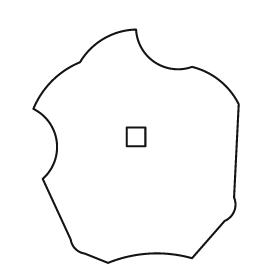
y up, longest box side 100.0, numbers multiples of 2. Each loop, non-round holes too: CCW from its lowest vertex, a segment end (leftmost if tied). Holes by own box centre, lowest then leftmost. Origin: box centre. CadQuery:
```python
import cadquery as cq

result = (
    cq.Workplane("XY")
    .moveTo(-12.0, -50.0)
    .threePointArc((6.0, -46.0), (24.0, -48.0))
    .lineTo(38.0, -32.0)
    .threePointArc((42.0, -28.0), (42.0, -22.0))
    .lineTo(44.0, 18.0)
    .threePointArc((36.0, 28.0), (24.0, 34.0))
    .threePointArc((8.0, 36.0), (0.0, 50.0))
    .threePointArc((-14.0, 46.0), (-24.0, 36.0))
    .threePointArc((-36.0, 28.0), (-44.0, 16.0))
    .threePointArc((-34.0, 2.0), (-40.0, -14.0))
    .lineTo(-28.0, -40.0)
    .threePointArc((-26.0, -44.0), (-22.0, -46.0))
    .close()
    .moveTo(-4.0, 0.0)
    .lineTo(4.0, 0.0)
    .lineTo(4.0, 8.0)
    .lineTo(-4.0, 8.0)
    .close()
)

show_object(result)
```